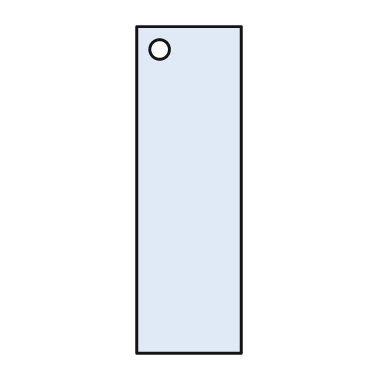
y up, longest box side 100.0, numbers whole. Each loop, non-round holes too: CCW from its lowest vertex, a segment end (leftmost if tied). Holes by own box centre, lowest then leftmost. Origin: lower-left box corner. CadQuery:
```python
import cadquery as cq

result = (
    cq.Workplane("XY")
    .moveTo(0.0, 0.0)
    .lineTo(32.0, 0.0)
    .lineTo(32.0, 100.0)
    .lineTo(0.0, 100.0)
    .close()
    .moveTo(7.0, 93.0)
    .circle(3.0)
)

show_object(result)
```